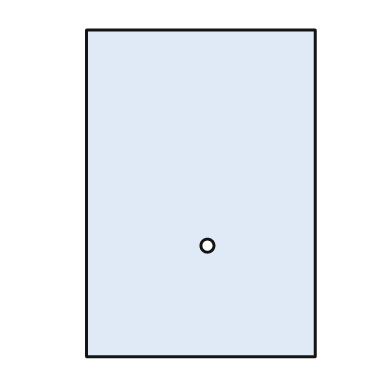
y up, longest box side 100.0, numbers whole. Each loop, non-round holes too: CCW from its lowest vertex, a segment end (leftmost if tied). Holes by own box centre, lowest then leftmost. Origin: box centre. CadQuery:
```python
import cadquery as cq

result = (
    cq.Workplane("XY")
    .moveTo(-35.0, -50.0)
    .lineTo(35.0, -50.0)
    .lineTo(35.0, 50.0)
    .lineTo(-35.0, 50.0)
    .close()
    .moveTo(2.0, -16.0)
    .circle(2.0)
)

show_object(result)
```